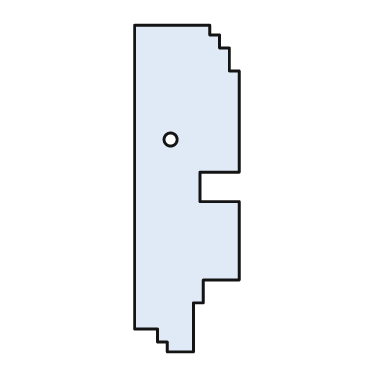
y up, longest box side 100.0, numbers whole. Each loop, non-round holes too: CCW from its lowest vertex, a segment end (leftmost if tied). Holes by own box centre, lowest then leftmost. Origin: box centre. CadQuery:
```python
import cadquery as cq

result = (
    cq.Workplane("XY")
    .moveTo(-6.0, -50.0)
    .lineTo(2.0, -50.0)
    .lineTo(2.0, -35.0)
    .lineTo(5.0, -35.0)
    .lineTo(5.0, -28.0)
    .lineTo(16.0, -28.0)
    .lineTo(16.0, -4.0)
    .lineTo(4.0, -4.0)
    .lineTo(4.0, 5.0)
    .lineTo(16.0, 5.0)
    .lineTo(16.0, 36.0)
    .lineTo(13.0, 36.0)
    .lineTo(13.0, 43.0)
    .lineTo(10.0, 43.0)
    .lineTo(10.0, 47.0)
    .lineTo(7.0, 47.0)
    .lineTo(7.0, 50.0)
    .lineTo(-16.0, 50.0)
    .lineTo(-16.0, -43.0)
    .lineTo(-9.0, -43.0)
    .lineTo(-9.0, -47.0)
    .lineTo(-6.0, -47.0)
    .close()
    .moveTo(-5.0, 15.0)
    .circle(2.0)
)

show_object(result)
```